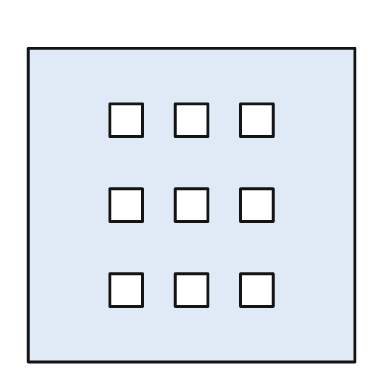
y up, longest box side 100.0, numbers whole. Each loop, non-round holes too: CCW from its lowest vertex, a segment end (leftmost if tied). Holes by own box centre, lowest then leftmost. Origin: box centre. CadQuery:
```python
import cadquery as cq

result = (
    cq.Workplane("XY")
    .moveTo(-50.0, -48.0)
    .lineTo(50.0, -48.0)
    .lineTo(50.0, 48.0)
    .lineTo(-50.0, 48.0)
    .close()
    .moveTo(-25.0, -31.0)
    .lineTo(-15.0, -31.0)
    .lineTo(-15.0, -21.0)
    .lineTo(-25.0, -21.0)
    .close()
    .moveTo(-5.0, -31.0)
    .lineTo(5.0, -31.0)
    .lineTo(5.0, -21.0)
    .lineTo(-5.0, -21.0)
    .close()
    .moveTo(15.0, -31.0)
    .lineTo(25.0, -31.0)
    .lineTo(25.0, -21.0)
    .lineTo(15.0, -21.0)
    .close()
    .moveTo(-25.0, -5.0)
    .lineTo(-15.0, -5.0)
    .lineTo(-15.0, 5.0)
    .lineTo(-25.0, 5.0)
    .close()
    .moveTo(-5.0, -5.0)
    .lineTo(5.0, -5.0)
    .lineTo(5.0, 5.0)
    .lineTo(-5.0, 5.0)
    .close()
    .moveTo(15.0, -5.0)
    .lineTo(25.0, -5.0)
    .lineTo(25.0, 5.0)
    .lineTo(15.0, 5.0)
    .close()
    .moveTo(-25.0, 21.0)
    .lineTo(-15.0, 21.0)
    .lineTo(-15.0, 31.0)
    .lineTo(-25.0, 31.0)
    .close()
    .moveTo(-5.0, 21.0)
    .lineTo(5.0, 21.0)
    .lineTo(5.0, 31.0)
    .lineTo(-5.0, 31.0)
    .close()
    .moveTo(15.0, 21.0)
    .lineTo(25.0, 21.0)
    .lineTo(25.0, 31.0)
    .lineTo(15.0, 31.0)
    .close()
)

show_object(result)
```